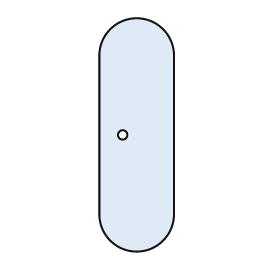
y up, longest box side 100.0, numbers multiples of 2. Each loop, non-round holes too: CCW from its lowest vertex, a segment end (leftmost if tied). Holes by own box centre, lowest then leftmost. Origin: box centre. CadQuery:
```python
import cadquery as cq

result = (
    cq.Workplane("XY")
    .moveTo(-16.0, -34.0)
    .threePointArc((0.0, -50.0), (16.0, -34.0))
    .lineTo(16.0, 34.0)
    .threePointArc((0.0, 50.0), (-16.0, 34.0))
    .close()
    .moveTo(-6.0, 0.0)
    .circle(2.0)
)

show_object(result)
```